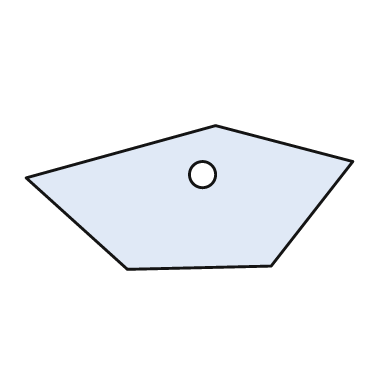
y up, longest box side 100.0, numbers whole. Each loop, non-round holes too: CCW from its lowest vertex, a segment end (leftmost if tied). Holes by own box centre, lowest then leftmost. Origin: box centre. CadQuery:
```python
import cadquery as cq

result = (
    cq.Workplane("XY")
    .moveTo(-19.0, -22.0)
    .lineTo(25.0, -21.0)
    .lineTo(50.0, 11.0)
    .lineTo(8.0, 22.0)
    .lineTo(-50.0, 6.0)
    .close()
    .moveTo(4.0, 7.0)
    .circle(4.0)
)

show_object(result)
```